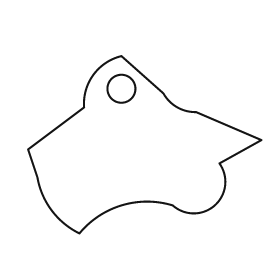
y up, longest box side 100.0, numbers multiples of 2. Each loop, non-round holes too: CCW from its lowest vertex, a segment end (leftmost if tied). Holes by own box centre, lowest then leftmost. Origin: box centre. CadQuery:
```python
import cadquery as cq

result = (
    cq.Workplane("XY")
    .moveTo(-28.0, -38.0)
    .threePointArc((-10.0, -26.0), (12.0, -26.0))
    .threePointArc((30.0, -26.0), (32.0, -8.0))
    .lineTo(50.0, 2.0)
    .lineTo(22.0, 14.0)
    .threePointArc((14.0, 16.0), (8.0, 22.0))
    .lineTo(-10.0, 38.0)
    .threePointArc((-22.0, 30.0), (-26.0, 16.0))
    .lineTo(-50.0, -2.0)
    .lineTo(-46.0, -14.0)
    .threePointArc((-40.0, -28.0), (-28.0, -38.0))
    .close()
    .moveTo(-10.0, 24.0)
    .circle(6.0)
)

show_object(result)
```